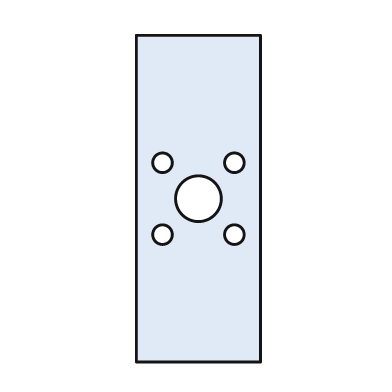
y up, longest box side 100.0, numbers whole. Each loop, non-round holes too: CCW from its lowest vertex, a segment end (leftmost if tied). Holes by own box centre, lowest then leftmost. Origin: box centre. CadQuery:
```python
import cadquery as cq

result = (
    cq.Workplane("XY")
    .moveTo(-19.0, -50.0)
    .lineTo(19.0, -50.0)
    .lineTo(19.0, 50.0)
    .lineTo(-19.0, 50.0)
    .close()
    .moveTo(-11.0, -11.0)
    .circle(3.0)
    .moveTo(11.0, -11.0)
    .circle(3.0)
    .moveTo(0.0, 0.0)
    .circle(7.0)
    .moveTo(-11.0, 11.0)
    .circle(3.0)
    .moveTo(11.0, 11.0)
    .circle(3.0)
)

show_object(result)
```